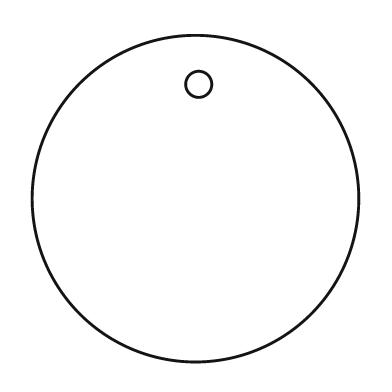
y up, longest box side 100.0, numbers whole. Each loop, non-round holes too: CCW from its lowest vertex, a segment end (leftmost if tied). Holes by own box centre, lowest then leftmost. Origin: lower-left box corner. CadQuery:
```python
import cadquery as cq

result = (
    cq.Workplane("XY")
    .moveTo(50.0, 50.0)
    .circle(50.0)
    .moveTo(51.0, 85.0)
    .circle(4.0)
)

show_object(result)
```